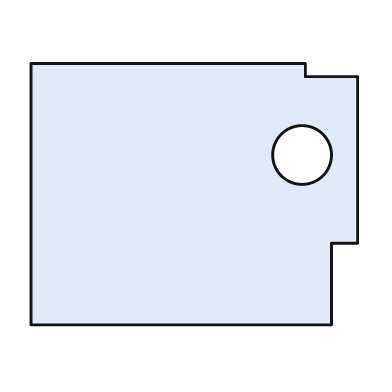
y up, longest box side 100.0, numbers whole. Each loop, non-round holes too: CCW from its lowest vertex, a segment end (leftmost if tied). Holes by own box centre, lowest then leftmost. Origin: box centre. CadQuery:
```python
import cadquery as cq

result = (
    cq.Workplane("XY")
    .moveTo(-50.0, -40.0)
    .lineTo(42.0, -40.0)
    .lineTo(42.0, -15.0)
    .lineTo(50.0, -15.0)
    .lineTo(50.0, 36.0)
    .lineTo(34.0, 36.0)
    .lineTo(34.0, 40.0)
    .lineTo(-50.0, 40.0)
    .close()
    .moveTo(33.0, 12.0)
    .circle(9.0)
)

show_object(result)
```